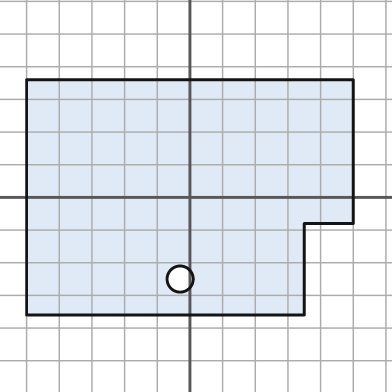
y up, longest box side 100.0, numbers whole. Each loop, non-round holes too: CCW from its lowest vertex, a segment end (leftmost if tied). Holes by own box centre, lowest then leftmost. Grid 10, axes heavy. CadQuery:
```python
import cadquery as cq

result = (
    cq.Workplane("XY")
    .moveTo(-50.0, -36.0)
    .lineTo(35.0, -36.0)
    .lineTo(35.0, -8.0)
    .lineTo(50.0, -8.0)
    .lineTo(50.0, 36.0)
    .lineTo(-50.0, 36.0)
    .close()
    .moveTo(-3.0, -25.0)
    .circle(4.0)
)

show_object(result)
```